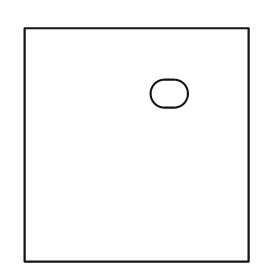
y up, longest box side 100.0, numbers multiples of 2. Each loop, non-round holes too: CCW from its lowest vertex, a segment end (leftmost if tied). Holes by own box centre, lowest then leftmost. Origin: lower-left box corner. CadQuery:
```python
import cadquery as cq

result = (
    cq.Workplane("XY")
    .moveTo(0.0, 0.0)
    .lineTo(96.0, 0.0)
    .lineTo(96.0, 100.0)
    .lineTo(0.0, 100.0)
    .close()
    .moveTo(60.0, 66.0)
    .lineTo(64.0, 66.0)
    .threePointArc((70.0, 72.0), (64.0, 78.0))
    .lineTo(60.0, 78.0)
    .threePointArc((54.0, 72.0), (60.0, 66.0))
    .close()
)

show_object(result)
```